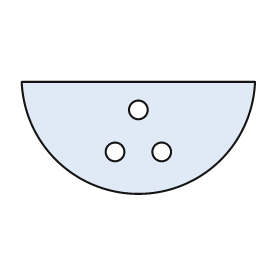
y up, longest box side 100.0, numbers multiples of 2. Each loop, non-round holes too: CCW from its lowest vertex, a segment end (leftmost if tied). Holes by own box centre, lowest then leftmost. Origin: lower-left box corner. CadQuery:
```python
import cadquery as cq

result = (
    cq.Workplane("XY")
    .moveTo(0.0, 48.0)
    .threePointArc((50.0, 0.0), (100.0, 48.0))
    .close()
    .moveTo(40.0, 18.0)
    .circle(4.0)
    .moveTo(60.0, 18.0)
    .circle(4.0)
    .moveTo(50.0, 36.0)
    .circle(4.0)
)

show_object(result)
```